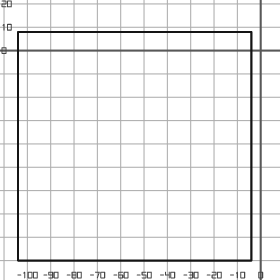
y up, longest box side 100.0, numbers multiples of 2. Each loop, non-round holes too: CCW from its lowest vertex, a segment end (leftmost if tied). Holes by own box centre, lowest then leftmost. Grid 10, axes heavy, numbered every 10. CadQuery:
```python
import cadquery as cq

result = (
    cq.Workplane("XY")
    .moveTo(-104.0, -90.0)
    .lineTo(-4.0, -90.0)
    .lineTo(-4.0, 8.0)
    .lineTo(-104.0, 8.0)
    .close()
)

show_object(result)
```